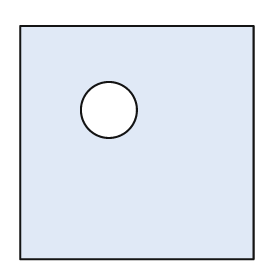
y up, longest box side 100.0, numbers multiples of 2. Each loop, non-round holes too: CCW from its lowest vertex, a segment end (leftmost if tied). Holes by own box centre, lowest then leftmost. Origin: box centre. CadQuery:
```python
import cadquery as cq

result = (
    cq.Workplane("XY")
    .moveTo(-50.0, -50.0)
    .lineTo(50.0, -50.0)
    .lineTo(50.0, 50.0)
    .lineTo(-50.0, 50.0)
    .close()
    .moveTo(-12.0, 14.0)
    .circle(12.0)
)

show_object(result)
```